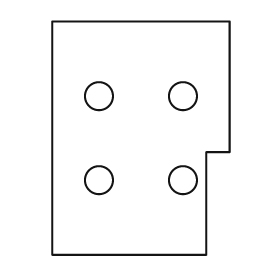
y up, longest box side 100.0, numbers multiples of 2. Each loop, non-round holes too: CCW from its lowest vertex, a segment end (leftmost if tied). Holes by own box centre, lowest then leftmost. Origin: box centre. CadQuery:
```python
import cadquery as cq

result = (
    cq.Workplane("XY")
    .moveTo(-38.0, -50.0)
    .lineTo(28.0, -50.0)
    .lineTo(28.0, -6.0)
    .lineTo(38.0, -6.0)
    .lineTo(38.0, 50.0)
    .lineTo(-38.0, 50.0)
    .close()
    .moveTo(-18.0, -18.0)
    .circle(6.0)
    .moveTo(18.0, -18.0)
    .circle(6.0)
    .moveTo(-18.0, 18.0)
    .circle(6.0)
    .moveTo(18.0, 18.0)
    .circle(6.0)
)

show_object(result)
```